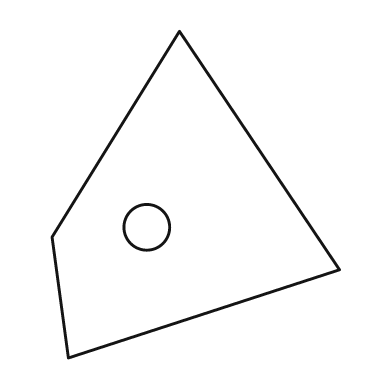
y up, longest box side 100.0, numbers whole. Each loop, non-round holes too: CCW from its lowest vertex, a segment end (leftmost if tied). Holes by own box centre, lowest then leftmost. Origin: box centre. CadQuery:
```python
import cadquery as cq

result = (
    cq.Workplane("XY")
    .moveTo(-39.0, -50.0)
    .lineTo(44.0, -23.0)
    .lineTo(-5.0, 50.0)
    .lineTo(-44.0, -13.0)
    .close()
    .moveTo(-15.0, -10.0)
    .circle(7.0)
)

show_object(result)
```